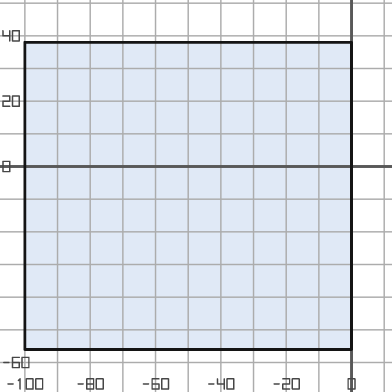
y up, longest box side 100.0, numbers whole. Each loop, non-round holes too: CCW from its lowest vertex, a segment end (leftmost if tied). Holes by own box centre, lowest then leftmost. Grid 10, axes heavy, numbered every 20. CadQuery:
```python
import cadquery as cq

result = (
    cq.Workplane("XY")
    .moveTo(-100.0, -56.0)
    .lineTo(0.0, -56.0)
    .lineTo(0.0, 38.0)
    .lineTo(-100.0, 38.0)
    .close()
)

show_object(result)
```